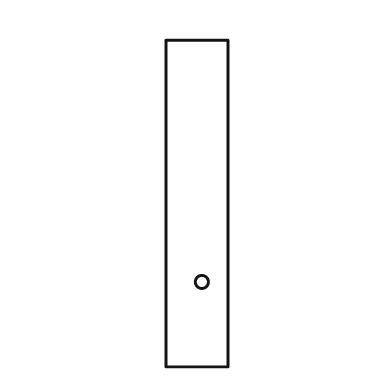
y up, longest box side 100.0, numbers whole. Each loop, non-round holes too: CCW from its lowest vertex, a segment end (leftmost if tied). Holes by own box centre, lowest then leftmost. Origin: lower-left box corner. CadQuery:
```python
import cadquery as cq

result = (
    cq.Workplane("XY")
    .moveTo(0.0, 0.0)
    .lineTo(19.0, 0.0)
    .lineTo(19.0, 100.0)
    .lineTo(0.0, 100.0)
    .close()
    .moveTo(11.0, 26.0)
    .circle(2.0)
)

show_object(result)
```